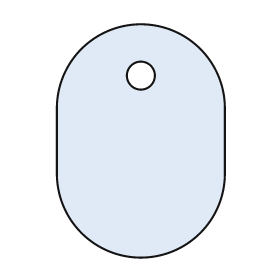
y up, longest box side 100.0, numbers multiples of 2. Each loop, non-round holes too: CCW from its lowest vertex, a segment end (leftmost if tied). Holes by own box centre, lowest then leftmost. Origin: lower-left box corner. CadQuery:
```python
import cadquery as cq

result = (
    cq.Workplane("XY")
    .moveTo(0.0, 36.0)
    .threePointArc((36.0, 0.0), (72.0, 36.0))
    .lineTo(72.0, 64.0)
    .threePointArc((36.0, 100.0), (0.0, 64.0))
    .close()
    .moveTo(36.0, 78.0)
    .circle(6.0)
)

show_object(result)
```